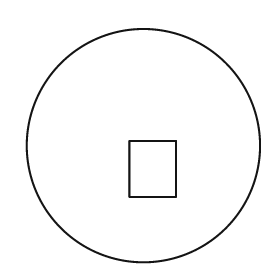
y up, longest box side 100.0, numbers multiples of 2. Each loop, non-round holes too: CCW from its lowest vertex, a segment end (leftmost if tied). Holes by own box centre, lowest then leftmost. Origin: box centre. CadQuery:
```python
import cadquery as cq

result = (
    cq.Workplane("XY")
    .moveTo(0.0, 0.0)
    .circle(50.0)
    .moveTo(-6.0, -22.0)
    .lineTo(14.0, -22.0)
    .lineTo(14.0, 2.0)
    .lineTo(-6.0, 2.0)
    .close()
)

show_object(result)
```